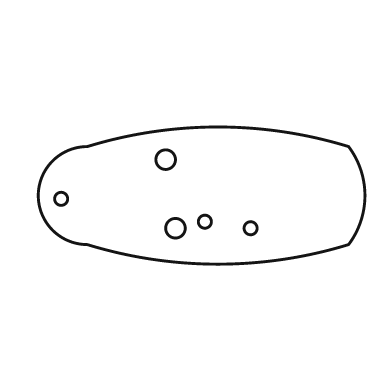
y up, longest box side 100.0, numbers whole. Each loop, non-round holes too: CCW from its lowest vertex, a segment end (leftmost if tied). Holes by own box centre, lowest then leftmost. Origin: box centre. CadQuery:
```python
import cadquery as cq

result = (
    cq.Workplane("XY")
    .moveTo(-35.0, -15.0)
    .threePointArc((5.0, -21.0), (45.0, -15.0))
    .threePointArc((50.0, 0.0), (45.0, 15.0))
    .threePointArc((5.0, 21.0), (-35.0, 15.0))
    .threePointArc((-50.0, 0.0), (-35.0, -15.0))
    .close()
    .moveTo(-8.0, -10.0)
    .circle(3.0)
    .moveTo(15.0, -10.0)
    .circle(2.0)
    .moveTo(1.0, -8.0)
    .circle(2.0)
    .moveTo(-43.0, -1.0)
    .circle(2.0)
    .moveTo(-11.0, 11.0)
    .circle(3.0)
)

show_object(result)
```